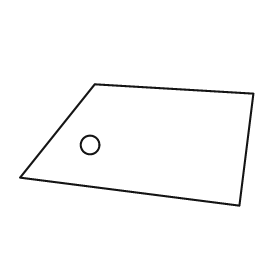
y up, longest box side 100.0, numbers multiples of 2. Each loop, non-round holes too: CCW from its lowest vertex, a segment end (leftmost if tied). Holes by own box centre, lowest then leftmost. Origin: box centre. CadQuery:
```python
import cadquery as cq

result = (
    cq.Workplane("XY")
    .moveTo(44.0, -26.0)
    .lineTo(50.0, 22.0)
    .lineTo(-18.0, 26.0)
    .lineTo(-50.0, -14.0)
    .close()
    .moveTo(-20.0, 0.0)
    .circle(4.0)
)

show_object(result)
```